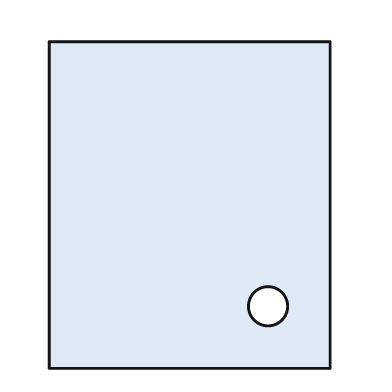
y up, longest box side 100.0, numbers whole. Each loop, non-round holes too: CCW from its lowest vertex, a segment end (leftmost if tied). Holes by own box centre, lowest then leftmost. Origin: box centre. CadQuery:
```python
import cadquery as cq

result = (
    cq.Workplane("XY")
    .moveTo(-43.0, -50.0)
    .lineTo(43.0, -50.0)
    .lineTo(43.0, 50.0)
    .lineTo(-43.0, 50.0)
    .close()
    .moveTo(24.0, -31.0)
    .circle(6.0)
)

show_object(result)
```